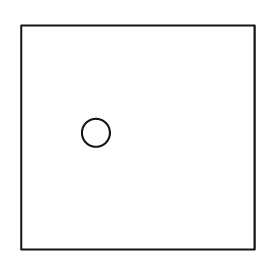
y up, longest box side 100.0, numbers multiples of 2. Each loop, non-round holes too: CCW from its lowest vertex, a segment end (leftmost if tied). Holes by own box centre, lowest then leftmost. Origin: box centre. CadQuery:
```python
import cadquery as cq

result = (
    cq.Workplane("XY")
    .moveTo(-50.0, -48.0)
    .lineTo(50.0, -48.0)
    .lineTo(50.0, 48.0)
    .lineTo(-50.0, 48.0)
    .close()
    .moveTo(-18.0, 2.0)
    .circle(6.0)
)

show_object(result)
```